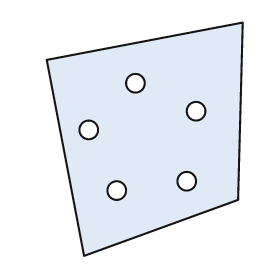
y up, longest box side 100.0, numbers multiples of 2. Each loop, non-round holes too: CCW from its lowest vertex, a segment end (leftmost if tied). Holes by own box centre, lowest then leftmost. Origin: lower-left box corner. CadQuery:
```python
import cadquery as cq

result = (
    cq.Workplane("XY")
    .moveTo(16.0, 0.0)
    .lineTo(82.0, 24.0)
    .lineTo(84.0, 100.0)
    .lineTo(0.0, 84.0)
    .close()
    .moveTo(30.0, 28.0)
    .circle(4.0)
    .moveTo(60.0, 32.0)
    .circle(4.0)
    .moveTo(18.0, 54.0)
    .circle(4.0)
    .moveTo(64.0, 62.0)
    .circle(4.0)
    .moveTo(38.0, 74.0)
    .circle(4.0)
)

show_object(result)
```